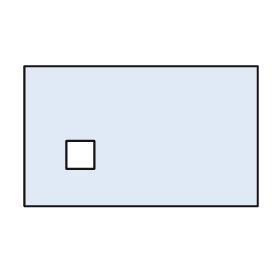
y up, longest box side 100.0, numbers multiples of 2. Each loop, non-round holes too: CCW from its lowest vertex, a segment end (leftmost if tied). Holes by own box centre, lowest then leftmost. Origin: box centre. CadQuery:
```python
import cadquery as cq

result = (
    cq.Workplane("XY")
    .moveTo(-50.0, -30.0)
    .lineTo(50.0, -30.0)
    .lineTo(50.0, 30.0)
    .lineTo(-50.0, 30.0)
    .close()
    .moveTo(-32.0, -14.0)
    .lineTo(-20.0, -14.0)
    .lineTo(-20.0, -2.0)
    .lineTo(-32.0, -2.0)
    .close()
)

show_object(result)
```